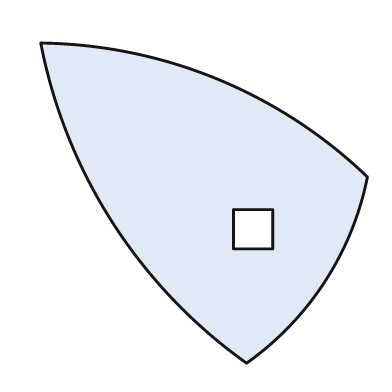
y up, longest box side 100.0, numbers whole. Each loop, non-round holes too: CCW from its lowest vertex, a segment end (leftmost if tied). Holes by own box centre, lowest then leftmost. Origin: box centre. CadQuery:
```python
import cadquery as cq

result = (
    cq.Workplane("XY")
    .moveTo(13.0, -49.0)
    .threePointArc((37.0, -24.0), (50.0, 8.0))
    .threePointArc((4.0, 38.0), (-50.0, 49.0))
    .threePointArc((-28.0, -6.0), (13.0, -49.0))
    .close()
    .moveTo(9.0, -14.0)
    .lineTo(21.0, -14.0)
    .lineTo(21.0, -2.0)
    .lineTo(9.0, -2.0)
    .close()
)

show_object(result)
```